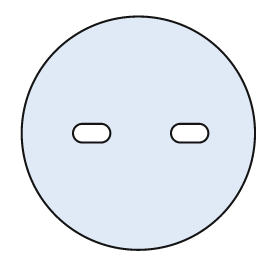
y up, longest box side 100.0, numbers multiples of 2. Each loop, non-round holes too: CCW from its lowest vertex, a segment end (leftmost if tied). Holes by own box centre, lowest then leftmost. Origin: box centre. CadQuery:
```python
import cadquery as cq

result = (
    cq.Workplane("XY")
    .moveTo(0.0, 0.0)
    .circle(50.0)
    .moveTo(-24.0, -4.0)
    .lineTo(-16.0, -4.0)
    .threePointArc((-12.0, 0.0), (-16.0, 4.0))
    .lineTo(-24.0, 4.0)
    .threePointArc((-28.0, 0.0), (-24.0, -4.0))
    .close()
    .moveTo(18.0, -4.0)
    .lineTo(26.0, -4.0)
    .threePointArc((30.0, 0.0), (26.0, 4.0))
    .lineTo(18.0, 4.0)
    .threePointArc((14.0, 0.0), (18.0, -4.0))
    .close()
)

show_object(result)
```